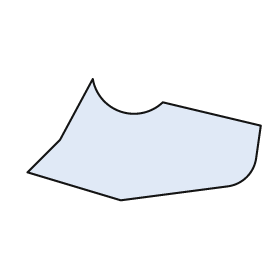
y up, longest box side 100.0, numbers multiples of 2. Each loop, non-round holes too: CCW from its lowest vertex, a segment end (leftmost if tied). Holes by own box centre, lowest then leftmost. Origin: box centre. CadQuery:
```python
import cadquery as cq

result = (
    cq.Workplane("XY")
    .moveTo(-10.0, -26.0)
    .lineTo(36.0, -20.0)
    .threePointArc((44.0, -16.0), (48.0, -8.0))
    .lineTo(50.0, 6.0)
    .lineTo(8.0, 16.0)
    .threePointArc((-10.0, 12.0), (-22.0, 26.0))
    .lineTo(-36.0, 0.0)
    .lineTo(-50.0, -14.0)
    .close()
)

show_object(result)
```